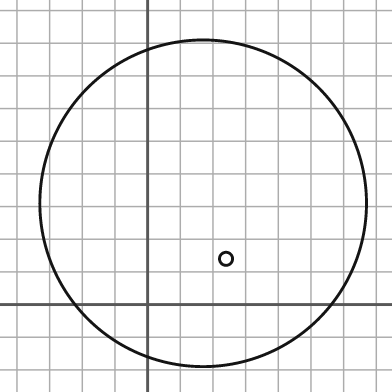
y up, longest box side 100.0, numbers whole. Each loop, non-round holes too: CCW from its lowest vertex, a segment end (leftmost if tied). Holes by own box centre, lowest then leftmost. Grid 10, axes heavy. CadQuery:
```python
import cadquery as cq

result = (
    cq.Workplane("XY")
    .moveTo(17.0, 31.0)
    .circle(50.0)
    .moveTo(24.0, 14.0)
    .circle(2.0)
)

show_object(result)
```